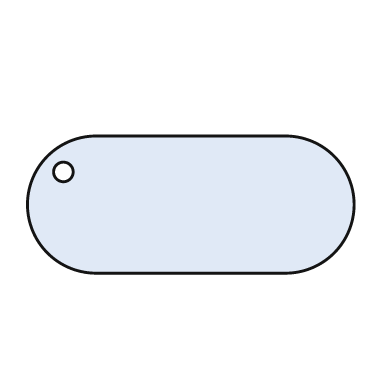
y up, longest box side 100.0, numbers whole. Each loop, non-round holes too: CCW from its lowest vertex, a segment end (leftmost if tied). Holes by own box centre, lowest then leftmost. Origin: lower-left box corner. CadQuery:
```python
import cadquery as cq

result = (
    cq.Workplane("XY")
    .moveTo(21.0, 0.0)
    .lineTo(79.0, 0.0)
    .threePointArc((100.0, 21.0), (79.0, 42.0))
    .lineTo(21.0, 42.0)
    .threePointArc((0.0, 21.0), (21.0, 0.0))
    .close()
    .moveTo(11.0, 31.0)
    .circle(3.0)
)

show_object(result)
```